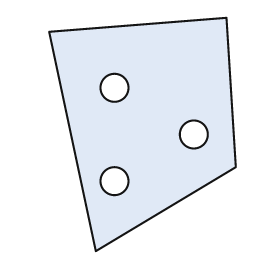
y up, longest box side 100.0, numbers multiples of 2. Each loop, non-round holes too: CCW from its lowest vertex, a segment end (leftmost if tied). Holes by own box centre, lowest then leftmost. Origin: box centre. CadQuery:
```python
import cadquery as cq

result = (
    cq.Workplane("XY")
    .moveTo(-20.0, -50.0)
    .lineTo(40.0, -14.0)
    .lineTo(36.0, 50.0)
    .lineTo(-40.0, 44.0)
    .close()
    .moveTo(-12.0, -20.0)
    .circle(6.0)
    .moveTo(22.0, 0.0)
    .circle(6.0)
    .moveTo(-12.0, 20.0)
    .circle(6.0)
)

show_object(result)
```